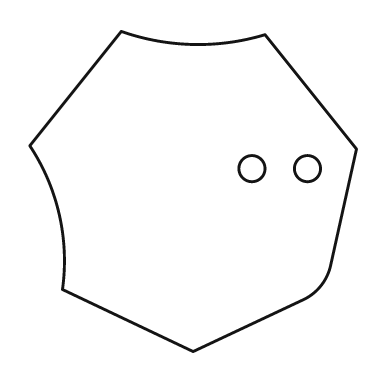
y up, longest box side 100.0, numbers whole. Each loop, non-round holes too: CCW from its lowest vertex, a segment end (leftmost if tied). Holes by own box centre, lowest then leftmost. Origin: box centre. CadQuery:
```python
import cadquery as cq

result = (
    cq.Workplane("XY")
    .moveTo(0.0, -49.0)
    .lineTo(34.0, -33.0)
    .threePointArc((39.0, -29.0), (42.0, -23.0))
    .lineTo(50.0, 13.0)
    .lineTo(22.0, 48.0)
    .threePointArc((0.0, 45.0), (-22.0, 49.0))
    .lineTo(-50.0, 14.0)
    .threePointArc((-41.0, -7.0), (-40.0, -30.0))
    .close()
    .moveTo(18.0, 7.0)
    .circle(4.0)
    .moveTo(35.0, 7.0)
    .circle(4.0)
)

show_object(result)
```